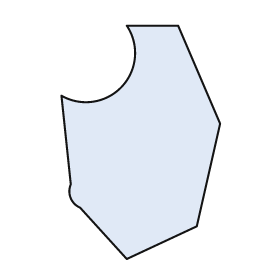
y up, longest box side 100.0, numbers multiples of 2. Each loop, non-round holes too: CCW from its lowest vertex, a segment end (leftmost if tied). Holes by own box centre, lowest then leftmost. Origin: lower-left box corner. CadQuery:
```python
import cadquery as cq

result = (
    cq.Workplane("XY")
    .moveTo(28.0, 0.0)
    .lineTo(58.0, 14.0)
    .lineTo(68.0, 58.0)
    .lineTo(50.0, 100.0)
    .lineTo(28.0, 100.0)
    .threePointArc((26.0, 74.0), (0.0, 70.0))
    .lineTo(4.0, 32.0)
    .threePointArc((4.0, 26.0), (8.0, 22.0))
    .close()
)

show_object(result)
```